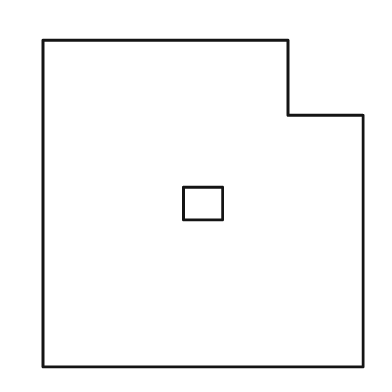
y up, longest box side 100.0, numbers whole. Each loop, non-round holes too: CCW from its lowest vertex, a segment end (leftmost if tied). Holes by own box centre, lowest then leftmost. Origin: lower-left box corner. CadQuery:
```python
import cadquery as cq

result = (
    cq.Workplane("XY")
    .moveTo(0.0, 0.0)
    .lineTo(98.0, 0.0)
    .lineTo(98.0, 77.0)
    .lineTo(75.0, 77.0)
    .lineTo(75.0, 100.0)
    .lineTo(0.0, 100.0)
    .close()
    .moveTo(43.0, 45.0)
    .lineTo(55.0, 45.0)
    .lineTo(55.0, 55.0)
    .lineTo(43.0, 55.0)
    .close()
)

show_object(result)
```